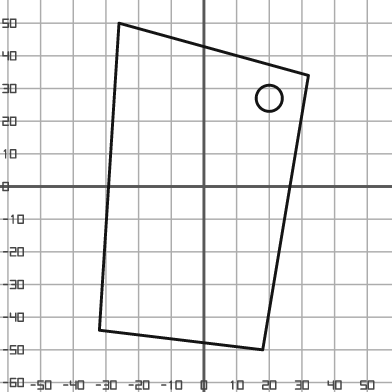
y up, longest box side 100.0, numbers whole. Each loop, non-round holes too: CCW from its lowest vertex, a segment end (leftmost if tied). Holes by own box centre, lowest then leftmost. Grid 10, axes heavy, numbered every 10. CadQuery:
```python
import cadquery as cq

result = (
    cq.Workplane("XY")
    .moveTo(18.0, -50.0)
    .lineTo(32.0, 34.0)
    .lineTo(-26.0, 50.0)
    .lineTo(-32.0, -44.0)
    .close()
    .moveTo(20.0, 27.0)
    .circle(4.0)
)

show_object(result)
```